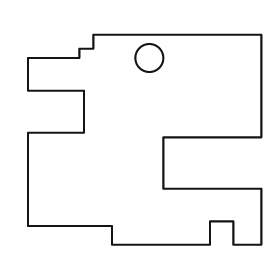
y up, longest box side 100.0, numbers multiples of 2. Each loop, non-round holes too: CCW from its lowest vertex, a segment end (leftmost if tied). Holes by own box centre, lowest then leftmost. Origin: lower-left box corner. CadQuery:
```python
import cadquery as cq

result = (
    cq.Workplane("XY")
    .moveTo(36.0, 0.0)
    .lineTo(78.0, 0.0)
    .lineTo(78.0, 10.0)
    .lineTo(88.0, 10.0)
    .lineTo(88.0, 0.0)
    .lineTo(100.0, 0.0)
    .lineTo(100.0, 24.0)
    .lineTo(58.0, 24.0)
    .lineTo(58.0, 46.0)
    .lineTo(100.0, 46.0)
    .lineTo(100.0, 90.0)
    .lineTo(28.0, 90.0)
    .lineTo(28.0, 84.0)
    .lineTo(22.0, 84.0)
    .lineTo(22.0, 80.0)
    .lineTo(0.0, 80.0)
    .lineTo(0.0, 66.0)
    .lineTo(24.0, 66.0)
    .lineTo(24.0, 48.0)
    .lineTo(0.0, 48.0)
    .lineTo(0.0, 8.0)
    .lineTo(36.0, 8.0)
    .close()
    .moveTo(52.0, 80.0)
    .circle(6.0)
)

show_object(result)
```